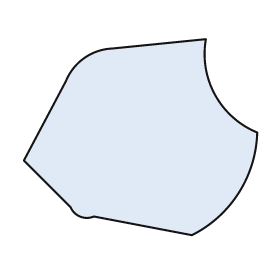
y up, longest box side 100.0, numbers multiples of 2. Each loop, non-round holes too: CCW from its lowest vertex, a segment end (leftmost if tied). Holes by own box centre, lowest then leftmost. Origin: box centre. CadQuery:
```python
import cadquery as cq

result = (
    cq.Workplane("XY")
    .moveTo(22.0, -42.0)
    .threePointArc((42.0, -24.0), (50.0, 2.0))
    .threePointArc((32.0, 18.0), (28.0, 42.0))
    .lineTo(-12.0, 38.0)
    .threePointArc((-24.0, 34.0), (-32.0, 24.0))
    .lineTo(-50.0, -10.0)
    .lineTo(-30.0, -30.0)
    .threePointArc((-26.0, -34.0), (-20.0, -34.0))
    .close()
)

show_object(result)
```